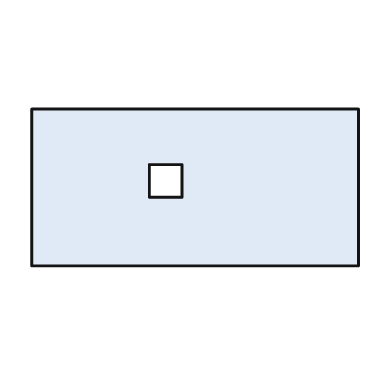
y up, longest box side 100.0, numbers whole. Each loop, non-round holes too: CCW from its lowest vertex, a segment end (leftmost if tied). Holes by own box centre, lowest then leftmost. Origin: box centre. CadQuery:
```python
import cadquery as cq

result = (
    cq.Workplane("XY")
    .moveTo(-50.0, -24.0)
    .lineTo(50.0, -24.0)
    .lineTo(50.0, 24.0)
    .lineTo(-50.0, 24.0)
    .close()
    .moveTo(-14.0, -3.0)
    .lineTo(-4.0, -3.0)
    .lineTo(-4.0, 7.0)
    .lineTo(-14.0, 7.0)
    .close()
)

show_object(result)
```